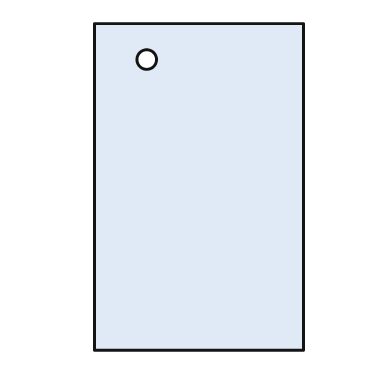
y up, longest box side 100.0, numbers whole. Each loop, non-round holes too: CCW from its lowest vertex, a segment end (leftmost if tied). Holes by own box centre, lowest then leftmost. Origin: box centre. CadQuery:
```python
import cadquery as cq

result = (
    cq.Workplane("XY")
    .moveTo(-32.0, -50.0)
    .lineTo(32.0, -50.0)
    .lineTo(32.0, 50.0)
    .lineTo(-32.0, 50.0)
    .close()
    .moveTo(-16.0, 39.0)
    .circle(3.0)
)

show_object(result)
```